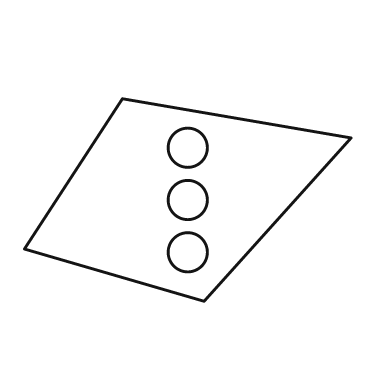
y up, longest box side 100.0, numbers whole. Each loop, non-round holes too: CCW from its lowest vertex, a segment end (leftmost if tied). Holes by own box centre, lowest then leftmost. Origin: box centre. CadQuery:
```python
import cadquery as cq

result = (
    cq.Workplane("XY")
    .moveTo(5.0, -31.0)
    .lineTo(50.0, 19.0)
    .lineTo(-20.0, 31.0)
    .lineTo(-50.0, -15.0)
    .close()
    .moveTo(0.0, -16.0)
    .circle(6.0)
    .moveTo(0.0, 0.0)
    .circle(6.0)
    .moveTo(0.0, 16.0)
    .circle(6.0)
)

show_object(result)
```